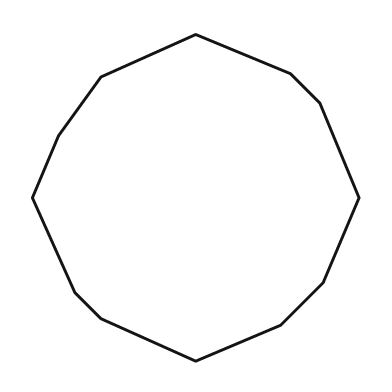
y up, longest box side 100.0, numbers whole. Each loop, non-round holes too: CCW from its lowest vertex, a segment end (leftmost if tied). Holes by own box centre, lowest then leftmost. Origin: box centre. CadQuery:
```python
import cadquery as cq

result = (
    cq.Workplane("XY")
    .moveTo(0.0, -50.0)
    .lineTo(26.0, -39.0)
    .lineTo(39.0, -26.0)
    .lineTo(50.0, 0.0)
    .lineTo(38.0, 29.0)
    .lineTo(29.0, 38.0)
    .lineTo(0.0, 50.0)
    .lineTo(-29.0, 37.0)
    .lineTo(-42.0, 19.0)
    .lineTo(-50.0, 0.0)
    .lineTo(-37.0, -29.0)
    .lineTo(-29.0, -37.0)
    .close()
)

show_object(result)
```